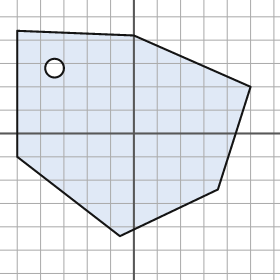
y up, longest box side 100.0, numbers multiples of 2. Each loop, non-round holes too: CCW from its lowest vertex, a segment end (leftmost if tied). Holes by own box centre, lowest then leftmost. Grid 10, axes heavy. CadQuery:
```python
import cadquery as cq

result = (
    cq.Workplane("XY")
    .moveTo(-6.0, -44.0)
    .lineTo(36.0, -24.0)
    .lineTo(50.0, 20.0)
    .lineTo(0.0, 42.0)
    .lineTo(-50.0, 44.0)
    .lineTo(-50.0, -10.0)
    .close()
    .moveTo(-34.0, 28.0)
    .circle(4.0)
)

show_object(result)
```